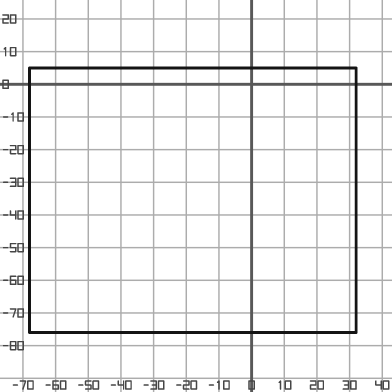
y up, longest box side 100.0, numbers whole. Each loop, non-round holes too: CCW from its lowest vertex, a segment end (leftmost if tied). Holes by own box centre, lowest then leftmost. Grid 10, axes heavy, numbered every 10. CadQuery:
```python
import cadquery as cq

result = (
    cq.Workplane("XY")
    .moveTo(-68.0, -76.0)
    .lineTo(32.0, -76.0)
    .lineTo(32.0, 5.0)
    .lineTo(-68.0, 5.0)
    .close()
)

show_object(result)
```